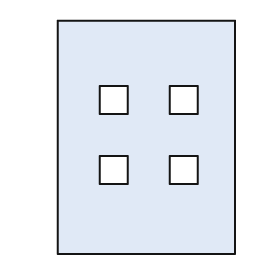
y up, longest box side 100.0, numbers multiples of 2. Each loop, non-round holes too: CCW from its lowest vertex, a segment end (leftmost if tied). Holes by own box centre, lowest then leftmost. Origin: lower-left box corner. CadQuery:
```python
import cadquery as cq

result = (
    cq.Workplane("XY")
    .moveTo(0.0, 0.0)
    .lineTo(76.0, 0.0)
    .lineTo(76.0, 100.0)
    .lineTo(0.0, 100.0)
    .close()
    .moveTo(18.0, 30.0)
    .lineTo(30.0, 30.0)
    .lineTo(30.0, 42.0)
    .lineTo(18.0, 42.0)
    .close()
    .moveTo(48.0, 30.0)
    .lineTo(60.0, 30.0)
    .lineTo(60.0, 42.0)
    .lineTo(48.0, 42.0)
    .close()
    .moveTo(18.0, 60.0)
    .lineTo(30.0, 60.0)
    .lineTo(30.0, 72.0)
    .lineTo(18.0, 72.0)
    .close()
    .moveTo(48.0, 60.0)
    .lineTo(60.0, 60.0)
    .lineTo(60.0, 72.0)
    .lineTo(48.0, 72.0)
    .close()
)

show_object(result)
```